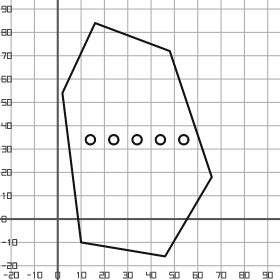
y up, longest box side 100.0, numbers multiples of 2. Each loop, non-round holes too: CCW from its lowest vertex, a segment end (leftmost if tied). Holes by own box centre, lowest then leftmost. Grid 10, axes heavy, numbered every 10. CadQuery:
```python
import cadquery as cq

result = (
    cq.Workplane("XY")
    .moveTo(46.0, -16.0)
    .lineTo(66.0, 18.0)
    .lineTo(48.0, 72.0)
    .lineTo(16.0, 84.0)
    .lineTo(2.0, 54.0)
    .lineTo(10.0, -10.0)
    .close()
    .moveTo(14.0, 34.0)
    .circle(2.0)
    .moveTo(24.0, 34.0)
    .circle(2.0)
    .moveTo(34.0, 34.0)
    .circle(2.0)
    .moveTo(44.0, 34.0)
    .circle(2.0)
    .moveTo(54.0, 34.0)
    .circle(2.0)
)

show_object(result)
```